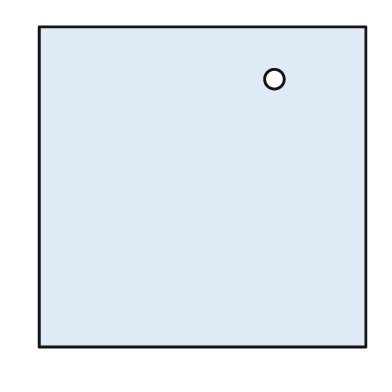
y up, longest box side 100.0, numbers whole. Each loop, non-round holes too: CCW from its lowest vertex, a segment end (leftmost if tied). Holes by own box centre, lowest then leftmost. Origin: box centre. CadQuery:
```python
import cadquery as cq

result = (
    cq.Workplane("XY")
    .moveTo(-50.0, -49.0)
    .lineTo(50.0, -49.0)
    .lineTo(50.0, 49.0)
    .lineTo(-50.0, 49.0)
    .close()
    .moveTo(22.0, 33.0)
    .circle(3.0)
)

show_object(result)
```